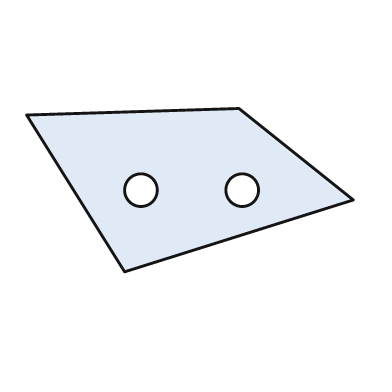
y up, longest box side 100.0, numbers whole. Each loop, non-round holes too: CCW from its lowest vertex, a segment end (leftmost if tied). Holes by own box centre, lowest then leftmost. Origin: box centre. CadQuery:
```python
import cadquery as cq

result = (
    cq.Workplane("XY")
    .moveTo(-20.0, -25.0)
    .lineTo(50.0, -3.0)
    .lineTo(15.0, 25.0)
    .lineTo(-50.0, 23.0)
    .close()
    .moveTo(-15.0, 0.0)
    .circle(5.0)
    .moveTo(16.0, 0.0)
    .circle(5.0)
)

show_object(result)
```